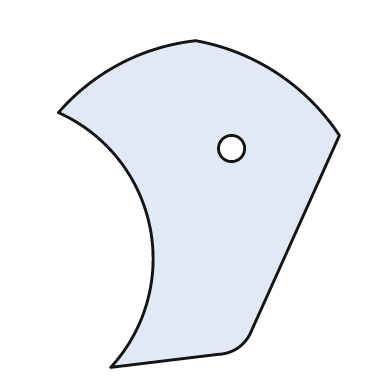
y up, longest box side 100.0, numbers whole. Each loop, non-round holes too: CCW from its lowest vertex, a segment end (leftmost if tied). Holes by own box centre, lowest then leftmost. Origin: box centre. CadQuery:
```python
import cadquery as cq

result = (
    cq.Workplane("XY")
    .moveTo(-27.0, -50.0)
    .lineTo(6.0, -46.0)
    .threePointArc((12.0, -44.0), (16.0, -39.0))
    .lineTo(43.0, 21.0)
    .threePointArc((24.0, 40.0), (-1.0, 50.0))
    .threePointArc((-24.0, 43.0), (-43.0, 28.0))
    .threePointArc((-15.0, -7.0), (-27.0, -50.0))
    .close()
    .moveTo(10.0, 17.0)
    .circle(4.0)
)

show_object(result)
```